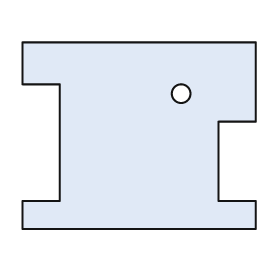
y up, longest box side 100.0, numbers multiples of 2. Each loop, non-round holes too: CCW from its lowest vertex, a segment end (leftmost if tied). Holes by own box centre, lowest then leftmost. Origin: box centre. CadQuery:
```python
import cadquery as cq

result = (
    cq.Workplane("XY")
    .moveTo(-50.0, -40.0)
    .lineTo(50.0, -40.0)
    .lineTo(50.0, -28.0)
    .lineTo(34.0, -28.0)
    .lineTo(34.0, 6.0)
    .lineTo(50.0, 6.0)
    .lineTo(50.0, 40.0)
    .lineTo(-50.0, 40.0)
    .lineTo(-50.0, 22.0)
    .lineTo(-34.0, 22.0)
    .lineTo(-34.0, -28.0)
    .lineTo(-50.0, -28.0)
    .close()
    .moveTo(18.0, 18.0)
    .circle(4.0)
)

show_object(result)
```